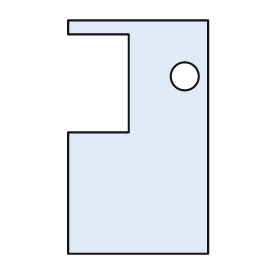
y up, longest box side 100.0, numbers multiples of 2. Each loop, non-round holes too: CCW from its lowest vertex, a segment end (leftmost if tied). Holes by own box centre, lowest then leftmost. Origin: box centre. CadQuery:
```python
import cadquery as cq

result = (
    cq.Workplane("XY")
    .moveTo(-30.0, -50.0)
    .lineTo(30.0, -50.0)
    .lineTo(30.0, 50.0)
    .lineTo(-30.0, 50.0)
    .lineTo(-30.0, 44.0)
    .lineTo(-4.0, 44.0)
    .lineTo(-4.0, 2.0)
    .lineTo(-30.0, 2.0)
    .close()
    .moveTo(20.0, 26.0)
    .circle(6.0)
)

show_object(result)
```